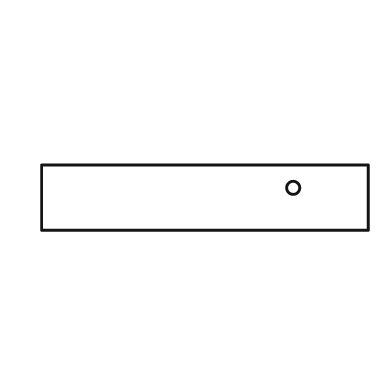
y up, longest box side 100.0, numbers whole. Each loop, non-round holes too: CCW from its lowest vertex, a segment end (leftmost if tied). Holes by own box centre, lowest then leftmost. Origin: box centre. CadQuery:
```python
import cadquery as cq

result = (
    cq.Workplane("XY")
    .moveTo(-50.0, -10.0)
    .lineTo(50.0, -10.0)
    .lineTo(50.0, 10.0)
    .lineTo(-50.0, 10.0)
    .close()
    .moveTo(27.0, 3.0)
    .circle(2.0)
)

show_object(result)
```